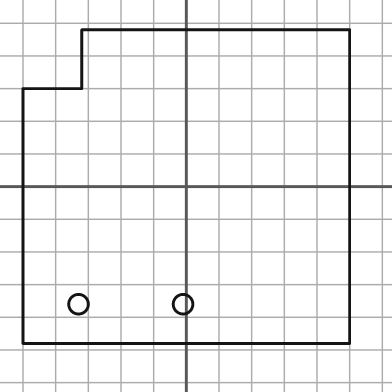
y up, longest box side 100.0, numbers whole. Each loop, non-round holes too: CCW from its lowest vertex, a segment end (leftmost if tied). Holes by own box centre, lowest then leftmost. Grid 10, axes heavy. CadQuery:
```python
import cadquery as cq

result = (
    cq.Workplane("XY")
    .moveTo(-50.0, -48.0)
    .lineTo(50.0, -48.0)
    .lineTo(50.0, 48.0)
    .lineTo(-32.0, 48.0)
    .lineTo(-32.0, 30.0)
    .lineTo(-50.0, 30.0)
    .close()
    .moveTo(-33.0, -36.0)
    .circle(3.0)
    .moveTo(-1.0, -36.0)
    .circle(3.0)
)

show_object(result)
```